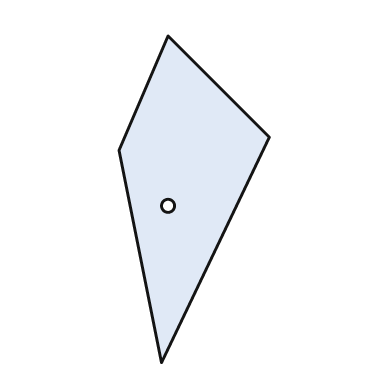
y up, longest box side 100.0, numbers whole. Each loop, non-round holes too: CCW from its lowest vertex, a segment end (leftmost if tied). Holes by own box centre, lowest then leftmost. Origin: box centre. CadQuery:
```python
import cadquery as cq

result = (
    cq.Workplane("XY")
    .moveTo(-10.0, -50.0)
    .lineTo(23.0, 19.0)
    .lineTo(-8.0, 50.0)
    .lineTo(-23.0, 15.0)
    .close()
    .moveTo(-8.0, -2.0)
    .circle(2.0)
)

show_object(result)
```